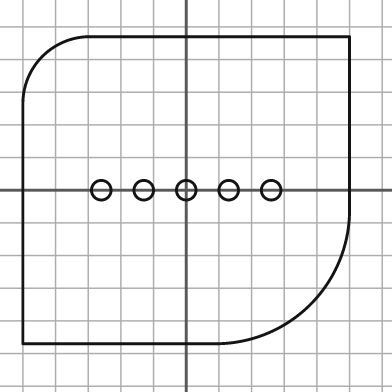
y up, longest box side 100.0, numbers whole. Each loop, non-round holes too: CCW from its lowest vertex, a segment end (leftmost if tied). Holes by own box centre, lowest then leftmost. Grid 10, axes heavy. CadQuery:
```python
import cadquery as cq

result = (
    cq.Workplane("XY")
    .moveTo(-50.0, -47.0)
    .lineTo(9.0, -47.0)
    .threePointArc((38.0, -35.0), (50.0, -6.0))
    .lineTo(50.0, 47.0)
    .lineTo(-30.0, 47.0)
    .threePointArc((-44.0, 41.0), (-50.0, 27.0))
    .close()
    .moveTo(-26.0, 0.0)
    .circle(3.0)
    .moveTo(-13.0, 0.0)
    .circle(3.0)
    .moveTo(0.0, 0.0)
    .circle(3.0)
    .moveTo(13.0, 0.0)
    .circle(3.0)
    .moveTo(26.0, 0.0)
    .circle(3.0)
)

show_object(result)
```